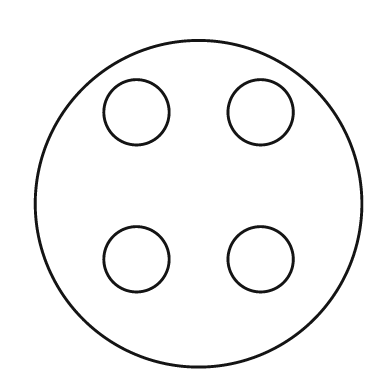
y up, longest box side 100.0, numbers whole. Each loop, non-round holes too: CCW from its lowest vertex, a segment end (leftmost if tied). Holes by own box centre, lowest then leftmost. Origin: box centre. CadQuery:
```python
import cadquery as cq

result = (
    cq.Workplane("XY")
    .moveTo(0.0, 0.0)
    .circle(50.0)
    .moveTo(-19.0, -17.0)
    .circle(10.0)
    .moveTo(19.0, -17.0)
    .circle(10.0)
    .moveTo(-19.0, 28.0)
    .circle(10.0)
    .moveTo(19.0, 28.0)
    .circle(10.0)
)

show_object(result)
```